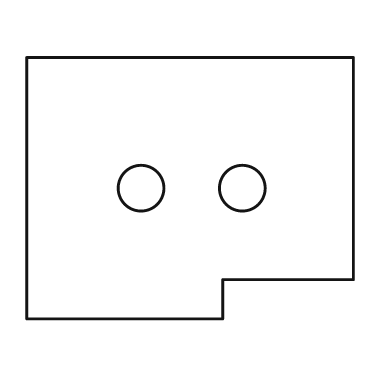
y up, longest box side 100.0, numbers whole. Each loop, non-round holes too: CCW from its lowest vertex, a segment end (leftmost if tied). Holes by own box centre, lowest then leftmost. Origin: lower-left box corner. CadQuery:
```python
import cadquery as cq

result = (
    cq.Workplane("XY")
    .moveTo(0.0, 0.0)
    .lineTo(60.0, 0.0)
    .lineTo(60.0, 12.0)
    .lineTo(100.0, 12.0)
    .lineTo(100.0, 80.0)
    .lineTo(0.0, 80.0)
    .close()
    .moveTo(35.0, 40.0)
    .circle(7.0)
    .moveTo(66.0, 40.0)
    .circle(7.0)
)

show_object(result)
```